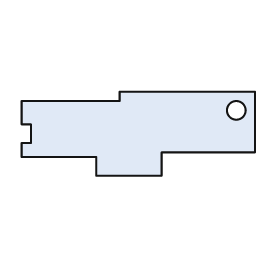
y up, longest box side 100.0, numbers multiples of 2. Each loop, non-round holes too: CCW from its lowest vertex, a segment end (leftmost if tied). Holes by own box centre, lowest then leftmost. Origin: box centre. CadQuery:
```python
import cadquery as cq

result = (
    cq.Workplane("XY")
    .moveTo(-18.0, -18.0)
    .lineTo(10.0, -18.0)
    .lineTo(10.0, -8.0)
    .lineTo(50.0, -8.0)
    .lineTo(50.0, 18.0)
    .lineTo(-8.0, 18.0)
    .lineTo(-8.0, 14.0)
    .lineTo(-50.0, 14.0)
    .lineTo(-50.0, 4.0)
    .lineTo(-46.0, 4.0)
    .lineTo(-46.0, -4.0)
    .lineTo(-50.0, -4.0)
    .lineTo(-50.0, -10.0)
    .lineTo(-18.0, -10.0)
    .close()
    .moveTo(42.0, 10.0)
    .circle(4.0)
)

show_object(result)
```